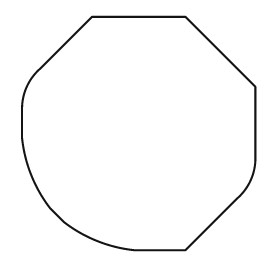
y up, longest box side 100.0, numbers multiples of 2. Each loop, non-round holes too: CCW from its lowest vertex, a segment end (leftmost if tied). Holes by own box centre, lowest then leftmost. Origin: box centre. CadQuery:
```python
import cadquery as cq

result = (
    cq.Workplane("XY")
    .moveTo(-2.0, -50.0)
    .lineTo(20.0, -50.0)
    .lineTo(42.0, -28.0)
    .threePointArc((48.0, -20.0), (50.0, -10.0))
    .lineTo(50.0, 20.0)
    .lineTo(20.0, 50.0)
    .lineTo(-20.0, 50.0)
    .lineTo(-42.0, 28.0)
    .threePointArc((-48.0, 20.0), (-50.0, 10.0))
    .lineTo(-50.0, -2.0)
    .threePointArc((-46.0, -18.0), (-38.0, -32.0))
    .lineTo(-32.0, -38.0)
    .threePointArc((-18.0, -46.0), (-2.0, -50.0))
    .close()
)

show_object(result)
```